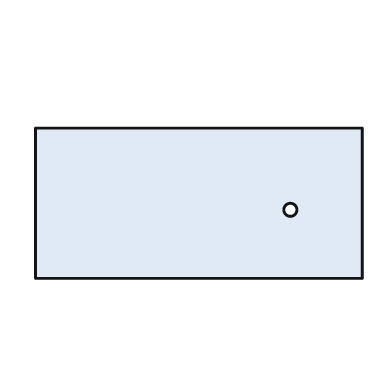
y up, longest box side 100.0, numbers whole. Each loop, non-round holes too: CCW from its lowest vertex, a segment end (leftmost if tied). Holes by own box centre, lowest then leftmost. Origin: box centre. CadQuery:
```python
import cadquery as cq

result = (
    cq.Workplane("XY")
    .moveTo(-50.0, -23.0)
    .lineTo(50.0, -23.0)
    .lineTo(50.0, 23.0)
    .lineTo(-50.0, 23.0)
    .close()
    .moveTo(28.0, -2.0)
    .circle(2.0)
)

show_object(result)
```